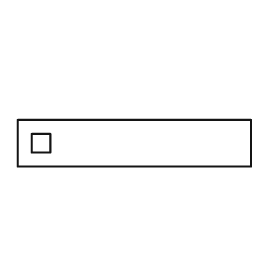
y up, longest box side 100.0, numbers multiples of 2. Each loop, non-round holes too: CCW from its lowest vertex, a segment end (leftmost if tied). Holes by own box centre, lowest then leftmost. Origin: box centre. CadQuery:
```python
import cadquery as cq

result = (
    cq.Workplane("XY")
    .moveTo(-50.0, -10.0)
    .lineTo(50.0, -10.0)
    .lineTo(50.0, 10.0)
    .lineTo(-50.0, 10.0)
    .close()
    .moveTo(-44.0, -4.0)
    .lineTo(-36.0, -4.0)
    .lineTo(-36.0, 4.0)
    .lineTo(-44.0, 4.0)
    .close()
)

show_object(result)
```